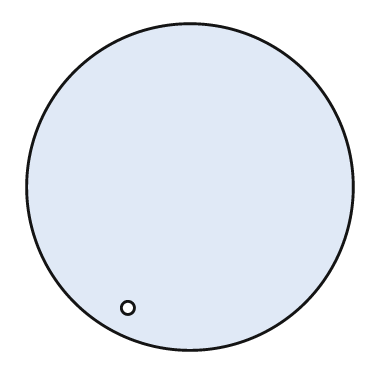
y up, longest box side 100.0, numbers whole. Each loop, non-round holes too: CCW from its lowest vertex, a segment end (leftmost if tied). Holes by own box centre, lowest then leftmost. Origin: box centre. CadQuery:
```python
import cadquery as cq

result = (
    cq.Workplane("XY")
    .moveTo(0.0, 0.0)
    .circle(50.0)
    .moveTo(-19.0, -37.0)
    .circle(2.0)
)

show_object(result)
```